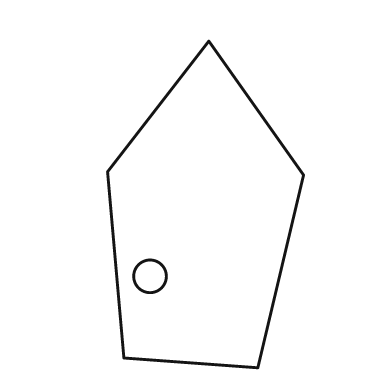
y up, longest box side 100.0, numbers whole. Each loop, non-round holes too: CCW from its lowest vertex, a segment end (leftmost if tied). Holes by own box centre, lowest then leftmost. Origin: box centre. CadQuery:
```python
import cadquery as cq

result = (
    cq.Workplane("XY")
    .moveTo(16.0, -50.0)
    .lineTo(30.0, 9.0)
    .lineTo(1.0, 50.0)
    .lineTo(-30.0, 10.0)
    .lineTo(-25.0, -47.0)
    .close()
    .moveTo(-17.0, -22.0)
    .circle(5.0)
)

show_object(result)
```